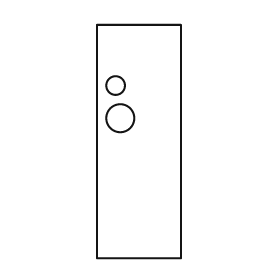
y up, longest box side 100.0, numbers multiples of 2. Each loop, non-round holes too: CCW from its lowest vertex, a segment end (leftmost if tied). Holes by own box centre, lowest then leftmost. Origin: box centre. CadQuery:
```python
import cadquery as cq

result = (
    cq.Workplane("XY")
    .moveTo(-18.0, -50.0)
    .lineTo(18.0, -50.0)
    .lineTo(18.0, 50.0)
    .lineTo(-18.0, 50.0)
    .close()
    .moveTo(-8.0, 10.0)
    .circle(6.0)
    .moveTo(-10.0, 24.0)
    .circle(4.0)
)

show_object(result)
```